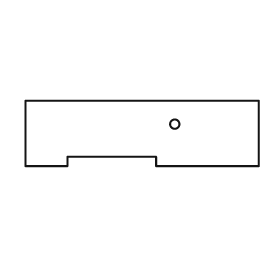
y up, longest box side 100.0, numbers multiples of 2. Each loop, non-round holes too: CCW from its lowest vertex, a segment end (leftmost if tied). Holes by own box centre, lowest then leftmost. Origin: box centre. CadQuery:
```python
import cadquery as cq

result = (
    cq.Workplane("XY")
    .moveTo(-50.0, -14.0)
    .lineTo(-32.0, -14.0)
    .lineTo(-32.0, -10.0)
    .lineTo(6.0, -10.0)
    .lineTo(6.0, -14.0)
    .lineTo(50.0, -14.0)
    .lineTo(50.0, 14.0)
    .lineTo(-50.0, 14.0)
    .close()
    .moveTo(14.0, 4.0)
    .circle(2.0)
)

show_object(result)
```